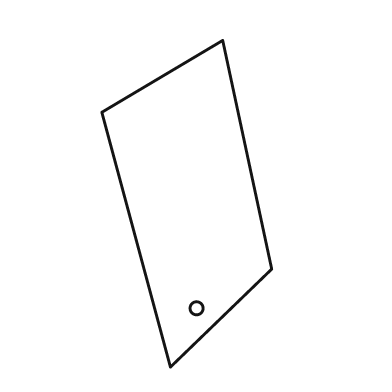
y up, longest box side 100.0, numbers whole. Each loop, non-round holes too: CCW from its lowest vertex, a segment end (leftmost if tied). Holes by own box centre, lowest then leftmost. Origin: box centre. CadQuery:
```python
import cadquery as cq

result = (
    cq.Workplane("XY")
    .moveTo(-5.0, -50.0)
    .lineTo(26.0, -20.0)
    .lineTo(11.0, 50.0)
    .lineTo(-26.0, 28.0)
    .close()
    .moveTo(3.0, -32.0)
    .circle(2.0)
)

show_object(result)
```